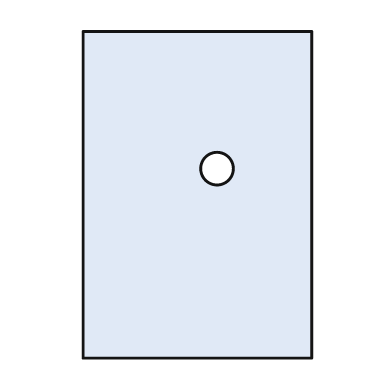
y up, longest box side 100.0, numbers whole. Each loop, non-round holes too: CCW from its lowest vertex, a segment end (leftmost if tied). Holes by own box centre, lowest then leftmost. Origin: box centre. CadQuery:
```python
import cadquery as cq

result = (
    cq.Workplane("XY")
    .moveTo(-35.0, -50.0)
    .lineTo(35.0, -50.0)
    .lineTo(35.0, 50.0)
    .lineTo(-35.0, 50.0)
    .close()
    .moveTo(6.0, 8.0)
    .circle(5.0)
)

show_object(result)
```